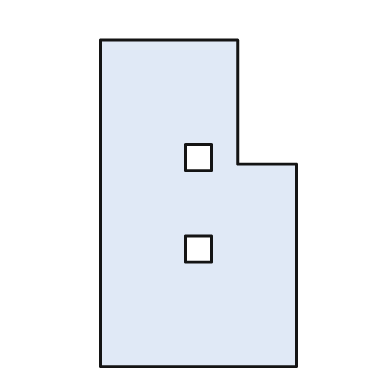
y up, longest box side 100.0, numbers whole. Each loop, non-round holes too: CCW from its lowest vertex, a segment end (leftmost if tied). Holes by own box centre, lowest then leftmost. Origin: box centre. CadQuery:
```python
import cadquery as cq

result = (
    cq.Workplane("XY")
    .moveTo(-30.0, -50.0)
    .lineTo(30.0, -50.0)
    .lineTo(30.0, 12.0)
    .lineTo(12.0, 12.0)
    .lineTo(12.0, 50.0)
    .lineTo(-30.0, 50.0)
    .close()
    .moveTo(-4.0, -18.0)
    .lineTo(4.0, -18.0)
    .lineTo(4.0, -10.0)
    .lineTo(-4.0, -10.0)
    .close()
    .moveTo(-4.0, 10.0)
    .lineTo(4.0, 10.0)
    .lineTo(4.0, 18.0)
    .lineTo(-4.0, 18.0)
    .close()
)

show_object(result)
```